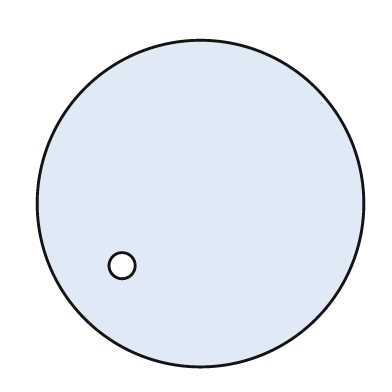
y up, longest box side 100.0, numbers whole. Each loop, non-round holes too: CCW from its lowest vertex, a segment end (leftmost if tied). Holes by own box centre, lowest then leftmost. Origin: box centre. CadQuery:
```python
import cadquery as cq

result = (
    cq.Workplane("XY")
    .moveTo(0.0, 0.0)
    .circle(50.0)
    .moveTo(-24.0, -19.0)
    .circle(4.0)
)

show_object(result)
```